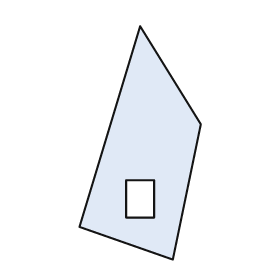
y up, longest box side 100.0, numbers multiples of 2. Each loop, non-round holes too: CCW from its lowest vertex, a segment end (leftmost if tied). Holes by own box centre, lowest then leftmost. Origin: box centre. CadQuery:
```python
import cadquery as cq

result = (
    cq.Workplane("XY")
    .moveTo(14.0, -50.0)
    .lineTo(26.0, 8.0)
    .lineTo(0.0, 50.0)
    .lineTo(-26.0, -36.0)
    .close()
    .moveTo(-6.0, -32.0)
    .lineTo(6.0, -32.0)
    .lineTo(6.0, -16.0)
    .lineTo(-6.0, -16.0)
    .close()
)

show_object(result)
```